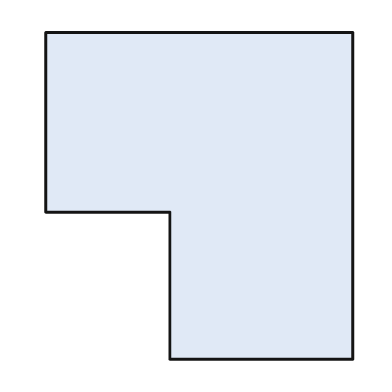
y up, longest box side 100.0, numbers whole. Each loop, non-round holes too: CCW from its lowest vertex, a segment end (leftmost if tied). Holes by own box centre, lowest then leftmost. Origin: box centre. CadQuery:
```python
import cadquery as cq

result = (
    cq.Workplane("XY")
    .moveTo(-9.0, -50.0)
    .lineTo(47.0, -50.0)
    .lineTo(47.0, 50.0)
    .lineTo(-47.0, 50.0)
    .lineTo(-47.0, -5.0)
    .lineTo(-9.0, -5.0)
    .close()
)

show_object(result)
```